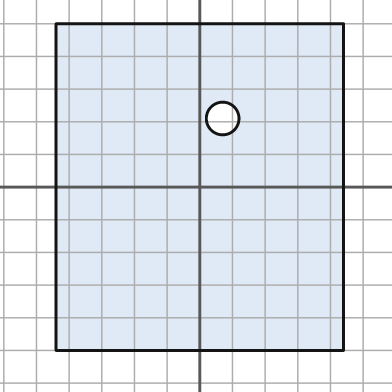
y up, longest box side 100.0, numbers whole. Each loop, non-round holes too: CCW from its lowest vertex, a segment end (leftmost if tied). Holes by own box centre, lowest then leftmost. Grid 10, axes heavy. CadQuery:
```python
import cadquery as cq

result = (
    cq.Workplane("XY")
    .moveTo(-44.0, -50.0)
    .lineTo(44.0, -50.0)
    .lineTo(44.0, 50.0)
    .lineTo(-44.0, 50.0)
    .close()
    .moveTo(7.0, 21.0)
    .circle(5.0)
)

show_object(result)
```